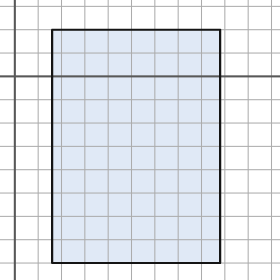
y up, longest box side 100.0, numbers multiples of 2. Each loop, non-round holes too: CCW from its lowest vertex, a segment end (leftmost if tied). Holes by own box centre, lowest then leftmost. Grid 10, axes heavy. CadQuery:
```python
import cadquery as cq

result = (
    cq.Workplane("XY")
    .moveTo(16.0, -80.0)
    .lineTo(88.0, -80.0)
    .lineTo(88.0, 20.0)
    .lineTo(16.0, 20.0)
    .close()
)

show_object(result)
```